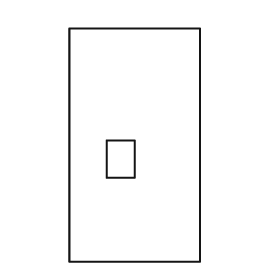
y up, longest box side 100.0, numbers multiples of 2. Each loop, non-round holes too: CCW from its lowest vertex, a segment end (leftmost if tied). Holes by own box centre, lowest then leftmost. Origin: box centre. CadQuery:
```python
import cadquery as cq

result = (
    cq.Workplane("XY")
    .moveTo(-28.0, -50.0)
    .lineTo(28.0, -50.0)
    .lineTo(28.0, 50.0)
    .lineTo(-28.0, 50.0)
    .close()
    .moveTo(-12.0, -14.0)
    .lineTo(0.0, -14.0)
    .lineTo(0.0, 2.0)
    .lineTo(-12.0, 2.0)
    .close()
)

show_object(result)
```